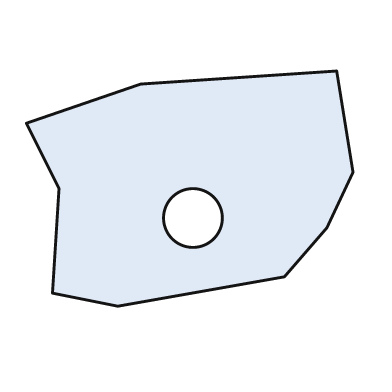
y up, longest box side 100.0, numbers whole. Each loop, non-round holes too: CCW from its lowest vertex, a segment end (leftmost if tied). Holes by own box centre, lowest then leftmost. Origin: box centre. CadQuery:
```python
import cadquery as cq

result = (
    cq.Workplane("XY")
    .moveTo(-22.0, -36.0)
    .lineTo(29.0, -27.0)
    .lineTo(42.0, -12.0)
    .lineTo(50.0, 5.0)
    .lineTo(45.0, 36.0)
    .lineTo(-15.0, 32.0)
    .lineTo(-50.0, 20.0)
    .lineTo(-40.0, 0.0)
    .lineTo(-42.0, -32.0)
    .close()
    .moveTo(1.0, -9.0)
    .circle(9.0)
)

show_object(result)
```